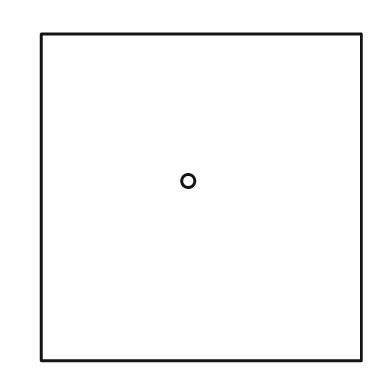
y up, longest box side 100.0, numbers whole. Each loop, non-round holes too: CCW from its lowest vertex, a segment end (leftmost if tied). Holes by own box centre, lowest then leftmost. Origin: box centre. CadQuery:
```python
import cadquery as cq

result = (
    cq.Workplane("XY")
    .moveTo(-49.0, -50.0)
    .lineTo(49.0, -50.0)
    .lineTo(49.0, 50.0)
    .lineTo(-49.0, 50.0)
    .close()
    .moveTo(-4.0, 5.0)
    .circle(2.0)
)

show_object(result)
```